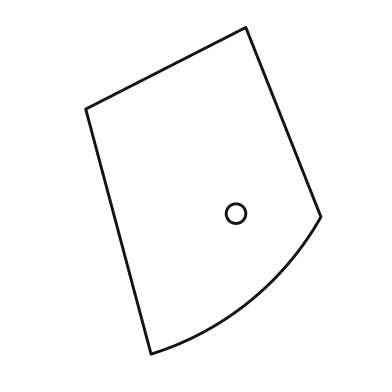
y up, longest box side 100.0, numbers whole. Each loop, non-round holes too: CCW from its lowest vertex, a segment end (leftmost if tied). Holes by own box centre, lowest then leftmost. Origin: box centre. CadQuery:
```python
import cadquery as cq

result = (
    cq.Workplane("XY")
    .moveTo(-16.0, -50.0)
    .threePointArc((14.0, -34.0), (36.0, -8.0))
    .lineTo(13.0, 50.0)
    .lineTo(-36.0, 25.0)
    .close()
    .moveTo(10.0, -7.0)
    .circle(3.0)
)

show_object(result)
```